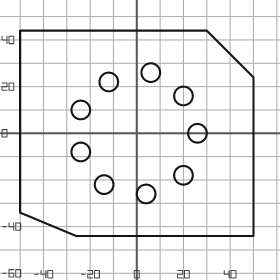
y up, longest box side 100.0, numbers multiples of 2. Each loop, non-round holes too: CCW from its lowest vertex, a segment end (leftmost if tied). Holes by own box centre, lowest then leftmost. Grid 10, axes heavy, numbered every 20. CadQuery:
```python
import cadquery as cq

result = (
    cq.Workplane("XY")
    .moveTo(-26.0, -44.0)
    .lineTo(50.0, -44.0)
    .lineTo(50.0, 24.0)
    .lineTo(30.0, 44.0)
    .lineTo(-50.0, 44.0)
    .lineTo(-50.0, -34.0)
    .close()
    .moveTo(4.0, -26.0)
    .circle(4.0)
    .moveTo(-14.0, -22.0)
    .circle(4.0)
    .moveTo(20.0, -18.0)
    .circle(4.0)
    .moveTo(-24.0, -8.0)
    .circle(4.0)
    .moveTo(26.0, 0.0)
    .circle(4.0)
    .moveTo(-24.0, 10.0)
    .circle(4.0)
    .moveTo(20.0, 16.0)
    .circle(4.0)
    .moveTo(-12.0, 22.0)
    .circle(4.0)
    .moveTo(6.0, 26.0)
    .circle(4.0)
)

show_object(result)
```